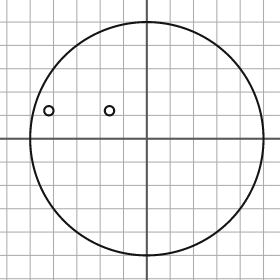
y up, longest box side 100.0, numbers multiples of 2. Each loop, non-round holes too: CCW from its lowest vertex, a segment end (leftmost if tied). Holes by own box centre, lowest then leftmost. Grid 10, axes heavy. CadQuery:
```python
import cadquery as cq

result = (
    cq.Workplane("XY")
    .moveTo(0.0, 0.0)
    .circle(50.0)
    .moveTo(-42.0, 12.0)
    .circle(2.0)
    .moveTo(-16.0, 12.0)
    .circle(2.0)
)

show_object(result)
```